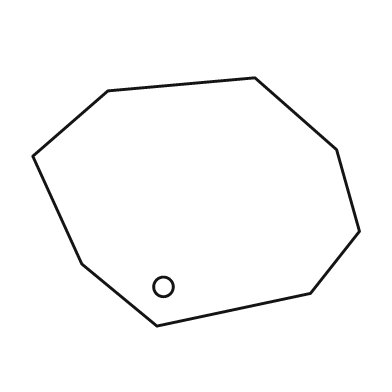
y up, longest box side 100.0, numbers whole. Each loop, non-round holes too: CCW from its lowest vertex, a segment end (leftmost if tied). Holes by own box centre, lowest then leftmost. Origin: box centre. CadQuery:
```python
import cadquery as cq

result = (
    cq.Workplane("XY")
    .moveTo(-12.0, -38.0)
    .lineTo(35.0, -28.0)
    .lineTo(50.0, -9.0)
    .lineTo(43.0, 16.0)
    .lineTo(18.0, 38.0)
    .lineTo(-27.0, 34.0)
    .lineTo(-50.0, 14.0)
    .lineTo(-35.0, -19.0)
    .close()
    .moveTo(-10.0, -26.0)
    .circle(3.0)
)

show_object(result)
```